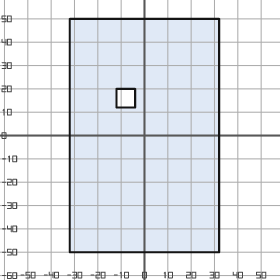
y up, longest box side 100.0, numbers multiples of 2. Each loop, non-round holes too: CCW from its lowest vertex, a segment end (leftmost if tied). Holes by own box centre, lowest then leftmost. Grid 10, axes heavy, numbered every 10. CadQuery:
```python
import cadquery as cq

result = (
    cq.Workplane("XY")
    .moveTo(-32.0, -50.0)
    .lineTo(32.0, -50.0)
    .lineTo(32.0, 50.0)
    .lineTo(-32.0, 50.0)
    .close()
    .moveTo(-12.0, 12.0)
    .lineTo(-4.0, 12.0)
    .lineTo(-4.0, 20.0)
    .lineTo(-12.0, 20.0)
    .close()
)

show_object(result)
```